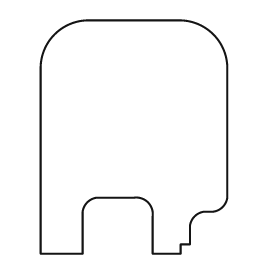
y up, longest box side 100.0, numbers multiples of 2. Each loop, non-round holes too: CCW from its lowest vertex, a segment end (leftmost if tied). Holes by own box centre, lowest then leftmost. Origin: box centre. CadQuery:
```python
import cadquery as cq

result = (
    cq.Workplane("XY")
    .moveTo(-40.0, -50.0)
    .lineTo(-22.0, -50.0)
    .lineTo(-22.0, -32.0)
    .threePointArc((-20.0, -28.0), (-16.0, -26.0))
    .lineTo(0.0, -26.0)
    .threePointArc((6.0, -28.0), (8.0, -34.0))
    .lineTo(8.0, -50.0)
    .lineTo(20.0, -50.0)
    .lineTo(20.0, -46.0)
    .lineTo(24.0, -46.0)
    .lineTo(24.0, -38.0)
    .threePointArc((26.0, -34.0), (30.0, -32.0))
    .lineTo(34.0, -32.0)
    .threePointArc((38.0, -30.0), (40.0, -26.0))
    .lineTo(40.0, 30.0)
    .threePointArc((34.0, 44.0), (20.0, 50.0))
    .lineTo(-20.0, 50.0)
    .threePointArc((-34.0, 44.0), (-40.0, 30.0))
    .close()
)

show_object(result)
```